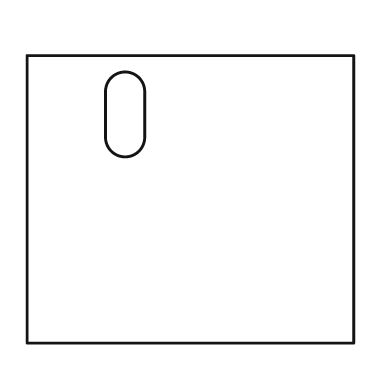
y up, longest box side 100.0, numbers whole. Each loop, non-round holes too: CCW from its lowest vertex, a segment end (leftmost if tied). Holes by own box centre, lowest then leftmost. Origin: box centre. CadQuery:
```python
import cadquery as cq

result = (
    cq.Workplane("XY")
    .moveTo(-50.0, -44.0)
    .lineTo(50.0, -44.0)
    .lineTo(50.0, 44.0)
    .lineTo(-50.0, 44.0)
    .close()
    .moveTo(-26.0, 19.0)
    .threePointArc((-20.0, 13.0), (-14.0, 19.0))
    .lineTo(-14.0, 33.0)
    .threePointArc((-20.0, 39.0), (-26.0, 33.0))
    .close()
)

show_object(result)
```